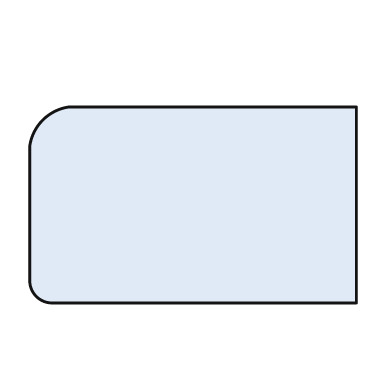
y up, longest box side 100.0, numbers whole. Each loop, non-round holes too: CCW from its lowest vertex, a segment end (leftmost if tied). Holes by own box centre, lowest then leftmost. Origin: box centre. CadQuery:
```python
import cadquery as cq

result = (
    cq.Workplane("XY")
    .moveTo(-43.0, -30.0)
    .lineTo(50.0, -30.0)
    .lineTo(50.0, 30.0)
    .lineTo(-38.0, 30.0)
    .threePointArc((-46.0, 26.0), (-50.0, 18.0))
    .lineTo(-50.0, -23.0)
    .threePointArc((-48.0, -28.0), (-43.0, -30.0))
    .close()
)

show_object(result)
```